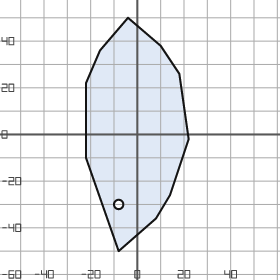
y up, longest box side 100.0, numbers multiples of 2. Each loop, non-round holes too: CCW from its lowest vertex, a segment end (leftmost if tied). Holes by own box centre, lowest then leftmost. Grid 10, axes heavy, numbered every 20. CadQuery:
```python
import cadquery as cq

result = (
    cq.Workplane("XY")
    .moveTo(-8.0, -50.0)
    .lineTo(8.0, -36.0)
    .lineTo(14.0, -26.0)
    .lineTo(22.0, -2.0)
    .lineTo(18.0, 26.0)
    .lineTo(10.0, 38.0)
    .lineTo(-4.0, 50.0)
    .lineTo(-16.0, 36.0)
    .lineTo(-22.0, 22.0)
    .lineTo(-22.0, -10.0)
    .close()
    .moveTo(-8.0, -30.0)
    .circle(2.0)
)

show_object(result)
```